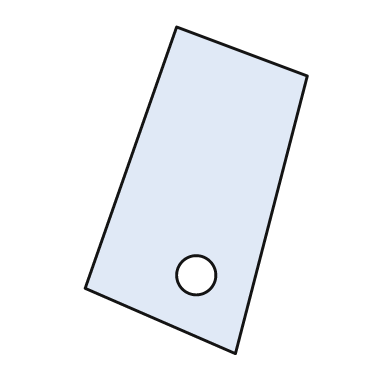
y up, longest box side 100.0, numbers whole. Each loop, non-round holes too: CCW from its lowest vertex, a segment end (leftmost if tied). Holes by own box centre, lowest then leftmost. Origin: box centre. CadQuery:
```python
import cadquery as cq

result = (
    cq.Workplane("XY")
    .moveTo(12.0, -50.0)
    .lineTo(34.0, 35.0)
    .lineTo(-6.0, 50.0)
    .lineTo(-34.0, -30.0)
    .close()
    .moveTo(0.0, -26.0)
    .circle(6.0)
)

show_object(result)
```